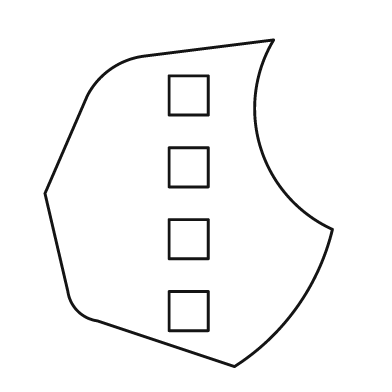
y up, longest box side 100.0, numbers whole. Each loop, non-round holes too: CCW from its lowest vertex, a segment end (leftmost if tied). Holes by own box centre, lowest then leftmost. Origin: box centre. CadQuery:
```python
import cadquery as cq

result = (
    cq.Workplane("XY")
    .moveTo(14.0, -50.0)
    .threePointArc((33.0, -32.0), (44.0, -8.0))
    .threePointArc((22.0, 17.0), (26.0, 50.0))
    .lineTo(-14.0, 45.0)
    .threePointArc((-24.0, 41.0), (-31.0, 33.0))
    .lineTo(-44.0, 3.0)
    .lineTo(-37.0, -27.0)
    .threePointArc((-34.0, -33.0), (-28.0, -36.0))
    .close()
    .moveTo(-6.0, -39.0)
    .lineTo(6.0, -39.0)
    .lineTo(6.0, -27.0)
    .lineTo(-6.0, -27.0)
    .close()
    .moveTo(-6.0, -17.0)
    .lineTo(6.0, -17.0)
    .lineTo(6.0, -5.0)
    .lineTo(-6.0, -5.0)
    .close()
    .moveTo(-6.0, 5.0)
    .lineTo(6.0, 5.0)
    .lineTo(6.0, 17.0)
    .lineTo(-6.0, 17.0)
    .close()
    .moveTo(-6.0, 27.0)
    .lineTo(6.0, 27.0)
    .lineTo(6.0, 39.0)
    .lineTo(-6.0, 39.0)
    .close()
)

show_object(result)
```